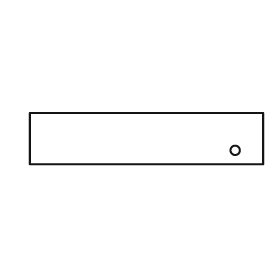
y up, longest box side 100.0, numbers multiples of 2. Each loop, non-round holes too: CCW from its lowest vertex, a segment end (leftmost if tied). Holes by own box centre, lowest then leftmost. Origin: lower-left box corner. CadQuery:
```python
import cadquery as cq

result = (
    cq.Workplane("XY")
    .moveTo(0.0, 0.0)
    .lineTo(100.0, 0.0)
    .lineTo(100.0, 22.0)
    .lineTo(0.0, 22.0)
    .close()
    .moveTo(88.0, 6.0)
    .circle(2.0)
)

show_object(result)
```